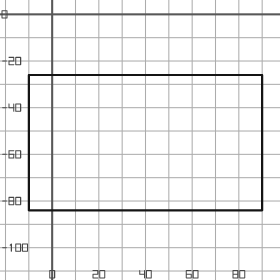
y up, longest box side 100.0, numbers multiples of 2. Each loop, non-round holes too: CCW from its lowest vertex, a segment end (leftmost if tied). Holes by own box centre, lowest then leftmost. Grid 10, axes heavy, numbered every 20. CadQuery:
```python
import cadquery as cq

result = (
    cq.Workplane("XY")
    .moveTo(-10.0, -84.0)
    .lineTo(90.0, -84.0)
    .lineTo(90.0, -26.0)
    .lineTo(-10.0, -26.0)
    .close()
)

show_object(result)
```